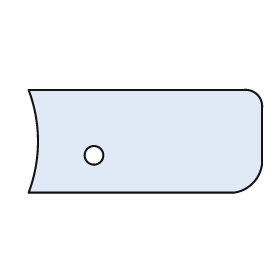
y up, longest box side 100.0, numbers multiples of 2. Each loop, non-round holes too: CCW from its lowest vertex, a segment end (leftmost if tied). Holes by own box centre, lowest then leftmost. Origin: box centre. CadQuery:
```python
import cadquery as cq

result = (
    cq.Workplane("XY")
    .moveTo(-50.0, -22.0)
    .lineTo(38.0, -22.0)
    .threePointArc((46.0, -18.0), (50.0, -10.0))
    .lineTo(50.0, 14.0)
    .threePointArc((48.0, 20.0), (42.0, 22.0))
    .lineTo(-50.0, 22.0)
    .threePointArc((-46.0, 0.0), (-50.0, -22.0))
    .close()
    .moveTo(-22.0, -6.0)
    .circle(4.0)
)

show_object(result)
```